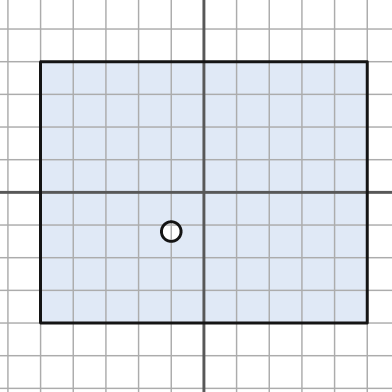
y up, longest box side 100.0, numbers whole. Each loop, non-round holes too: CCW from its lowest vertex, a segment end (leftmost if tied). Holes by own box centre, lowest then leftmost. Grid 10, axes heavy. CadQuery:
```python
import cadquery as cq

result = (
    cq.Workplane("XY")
    .moveTo(-50.0, -40.0)
    .lineTo(50.0, -40.0)
    .lineTo(50.0, 40.0)
    .lineTo(-50.0, 40.0)
    .close()
    .moveTo(-10.0, -12.0)
    .circle(3.0)
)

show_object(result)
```